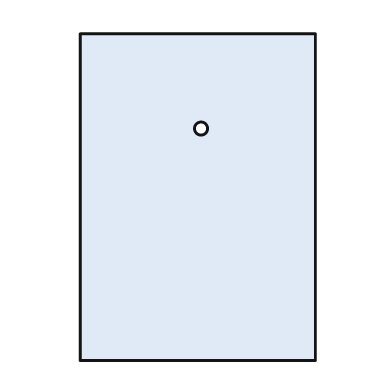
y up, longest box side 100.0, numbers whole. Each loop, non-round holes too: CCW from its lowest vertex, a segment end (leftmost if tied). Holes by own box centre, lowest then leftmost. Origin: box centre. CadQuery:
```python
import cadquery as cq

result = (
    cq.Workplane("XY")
    .moveTo(-36.0, -50.0)
    .lineTo(36.0, -50.0)
    .lineTo(36.0, 50.0)
    .lineTo(-36.0, 50.0)
    .close()
    .moveTo(1.0, 21.0)
    .circle(2.0)
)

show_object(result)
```